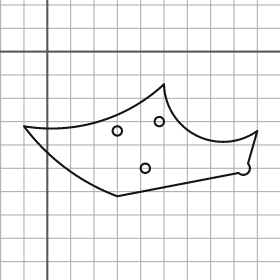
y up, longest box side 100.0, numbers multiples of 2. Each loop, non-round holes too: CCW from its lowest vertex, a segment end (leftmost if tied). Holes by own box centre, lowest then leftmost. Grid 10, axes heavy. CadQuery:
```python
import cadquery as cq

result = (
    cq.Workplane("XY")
    .moveTo(30.0, -62.0)
    .lineTo(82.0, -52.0)
    .threePointArc((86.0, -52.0), (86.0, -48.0))
    .lineTo(90.0, -34.0)
    .threePointArc((64.0, -36.0), (50.0, -14.0))
    .threePointArc((22.0, -30.0), (-10.0, -32.0))
    .threePointArc((8.0, -50.0), (30.0, -62.0))
    .close()
    .moveTo(42.0, -50.0)
    .circle(2.0)
    .moveTo(30.0, -34.0)
    .circle(2.0)
    .moveTo(48.0, -30.0)
    .circle(2.0)
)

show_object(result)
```